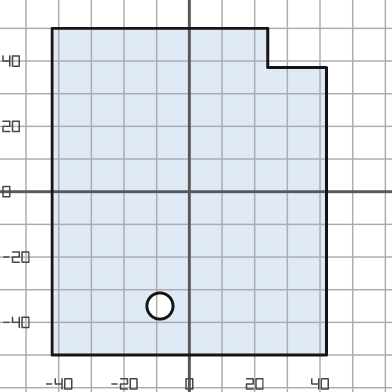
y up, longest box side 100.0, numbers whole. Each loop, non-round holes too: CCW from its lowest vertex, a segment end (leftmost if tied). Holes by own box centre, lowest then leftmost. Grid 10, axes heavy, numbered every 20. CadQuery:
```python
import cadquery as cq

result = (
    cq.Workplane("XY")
    .moveTo(-42.0, -50.0)
    .lineTo(42.0, -50.0)
    .lineTo(42.0, 38.0)
    .lineTo(24.0, 38.0)
    .lineTo(24.0, 50.0)
    .lineTo(-42.0, 50.0)
    .close()
    .moveTo(-9.0, -35.0)
    .circle(4.0)
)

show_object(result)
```